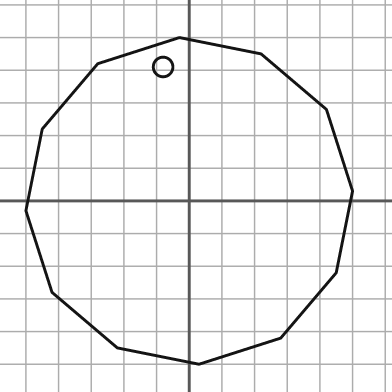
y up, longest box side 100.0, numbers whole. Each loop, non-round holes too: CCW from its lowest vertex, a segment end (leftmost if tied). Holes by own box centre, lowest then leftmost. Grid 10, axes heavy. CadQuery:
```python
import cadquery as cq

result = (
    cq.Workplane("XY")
    .moveTo(3.0, -50.0)
    .lineTo(28.0, -42.0)
    .lineTo(45.0, -22.0)
    .lineTo(50.0, 3.0)
    .lineTo(42.0, 28.0)
    .lineTo(22.0, 45.0)
    .lineTo(-3.0, 50.0)
    .lineTo(-28.0, 42.0)
    .lineTo(-45.0, 22.0)
    .lineTo(-50.0, -3.0)
    .lineTo(-42.0, -28.0)
    .lineTo(-22.0, -45.0)
    .close()
    .moveTo(-8.0, 41.0)
    .circle(3.0)
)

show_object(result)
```